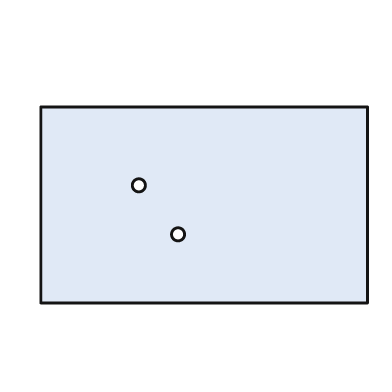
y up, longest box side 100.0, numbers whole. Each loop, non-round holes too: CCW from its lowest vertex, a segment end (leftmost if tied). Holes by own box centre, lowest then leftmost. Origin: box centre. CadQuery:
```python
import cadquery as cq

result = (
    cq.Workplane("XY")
    .moveTo(-50.0, -30.0)
    .lineTo(50.0, -30.0)
    .lineTo(50.0, 30.0)
    .lineTo(-50.0, 30.0)
    .close()
    .moveTo(-8.0, -9.0)
    .circle(2.0)
    .moveTo(-20.0, 6.0)
    .circle(2.0)
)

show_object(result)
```